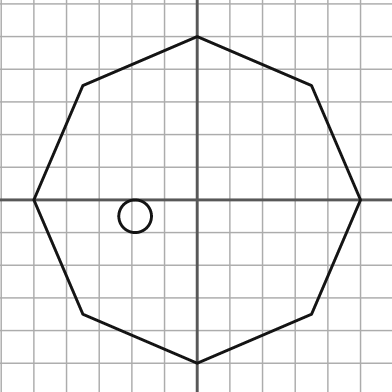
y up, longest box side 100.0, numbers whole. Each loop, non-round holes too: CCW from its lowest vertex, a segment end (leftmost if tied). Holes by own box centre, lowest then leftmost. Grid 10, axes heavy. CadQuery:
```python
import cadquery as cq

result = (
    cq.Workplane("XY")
    .moveTo(0.0, -50.0)
    .lineTo(35.0, -35.0)
    .lineTo(50.0, 0.0)
    .lineTo(35.0, 35.0)
    .lineTo(0.0, 50.0)
    .lineTo(-35.0, 35.0)
    .lineTo(-50.0, 0.0)
    .lineTo(-35.0, -35.0)
    .close()
    .moveTo(-19.0, -5.0)
    .circle(5.0)
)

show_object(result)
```